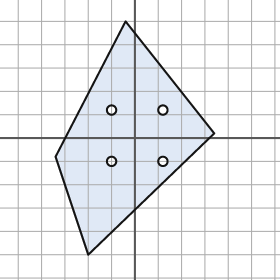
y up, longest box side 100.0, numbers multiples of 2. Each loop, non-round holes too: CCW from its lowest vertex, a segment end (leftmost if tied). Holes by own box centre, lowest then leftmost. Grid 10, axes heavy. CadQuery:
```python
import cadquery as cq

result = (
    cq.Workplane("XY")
    .moveTo(-20.0, -50.0)
    .lineTo(34.0, 2.0)
    .lineTo(-4.0, 50.0)
    .lineTo(-34.0, -8.0)
    .close()
    .moveTo(-10.0, -10.0)
    .circle(2.0)
    .moveTo(12.0, -10.0)
    .circle(2.0)
    .moveTo(-10.0, 12.0)
    .circle(2.0)
    .moveTo(12.0, 12.0)
    .circle(2.0)
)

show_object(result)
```